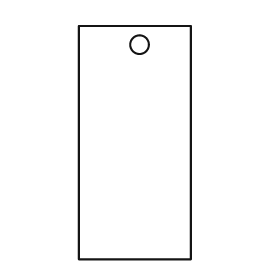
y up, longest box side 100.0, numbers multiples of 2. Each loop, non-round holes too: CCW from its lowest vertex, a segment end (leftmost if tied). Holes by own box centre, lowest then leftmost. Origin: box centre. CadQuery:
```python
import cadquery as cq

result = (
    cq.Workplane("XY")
    .moveTo(-24.0, -50.0)
    .lineTo(24.0, -50.0)
    .lineTo(24.0, 50.0)
    .lineTo(-24.0, 50.0)
    .close()
    .moveTo(2.0, 42.0)
    .circle(4.0)
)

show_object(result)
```